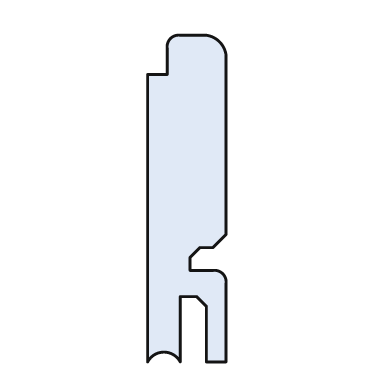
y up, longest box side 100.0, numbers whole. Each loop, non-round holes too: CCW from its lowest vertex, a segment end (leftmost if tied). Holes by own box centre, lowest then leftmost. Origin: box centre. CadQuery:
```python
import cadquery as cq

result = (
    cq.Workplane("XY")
    .moveTo(-12.0, -50.0)
    .threePointArc((-7.0, -47.0), (-2.0, -50.0))
    .lineTo(-2.0, -30.0)
    .lineTo(3.0, -30.0)
    .lineTo(6.0, -33.0)
    .lineTo(6.0, -50.0)
    .lineTo(12.0, -50.0)
    .lineTo(12.0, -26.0)
    .threePointArc((11.0, -23.0), (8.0, -22.0))
    .lineTo(1.0, -22.0)
    .lineTo(1.0, -18.0)
    .lineTo(4.0, -15.0)
    .lineTo(8.0, -15.0)
    .lineTo(12.0, -11.0)
    .lineTo(12.0, 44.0)
    .threePointArc((10.0, 48.0), (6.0, 50.0))
    .lineTo(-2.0, 50.0)
    .threePointArc((-5.0, 49.0), (-6.0, 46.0))
    .lineTo(-6.0, 38.0)
    .lineTo(-12.0, 38.0)
    .close()
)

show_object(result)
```